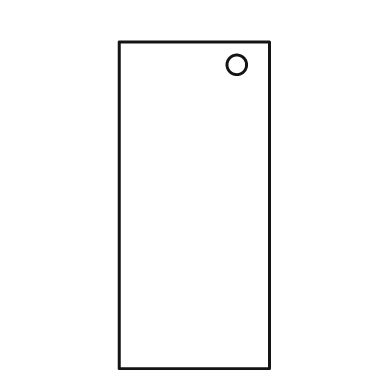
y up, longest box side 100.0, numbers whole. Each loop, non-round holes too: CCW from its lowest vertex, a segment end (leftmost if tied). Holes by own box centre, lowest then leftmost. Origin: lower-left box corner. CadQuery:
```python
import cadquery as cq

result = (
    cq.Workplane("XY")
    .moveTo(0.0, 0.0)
    .lineTo(46.0, 0.0)
    .lineTo(46.0, 100.0)
    .lineTo(0.0, 100.0)
    .close()
    .moveTo(36.0, 93.0)
    .circle(3.0)
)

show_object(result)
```